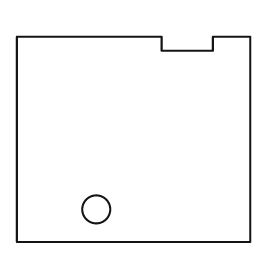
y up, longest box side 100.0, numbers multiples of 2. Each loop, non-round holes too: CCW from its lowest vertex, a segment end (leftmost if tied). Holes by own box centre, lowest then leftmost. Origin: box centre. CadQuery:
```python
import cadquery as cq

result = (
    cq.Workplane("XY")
    .moveTo(-50.0, -44.0)
    .lineTo(50.0, -44.0)
    .lineTo(50.0, 44.0)
    .lineTo(34.0, 44.0)
    .lineTo(34.0, 38.0)
    .lineTo(12.0, 38.0)
    .lineTo(12.0, 44.0)
    .lineTo(-50.0, 44.0)
    .close()
    .moveTo(-16.0, -30.0)
    .circle(6.0)
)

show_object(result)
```